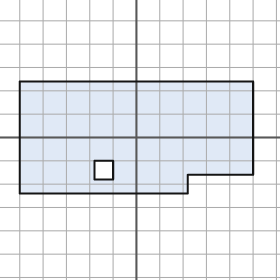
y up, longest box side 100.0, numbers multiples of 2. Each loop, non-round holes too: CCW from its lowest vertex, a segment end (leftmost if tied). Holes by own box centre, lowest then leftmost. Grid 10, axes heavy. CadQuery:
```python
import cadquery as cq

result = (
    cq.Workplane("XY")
    .moveTo(-50.0, -24.0)
    .lineTo(22.0, -24.0)
    .lineTo(22.0, -16.0)
    .lineTo(50.0, -16.0)
    .lineTo(50.0, 24.0)
    .lineTo(-50.0, 24.0)
    .close()
    .moveTo(-18.0, -18.0)
    .lineTo(-10.0, -18.0)
    .lineTo(-10.0, -10.0)
    .lineTo(-18.0, -10.0)
    .close()
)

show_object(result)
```